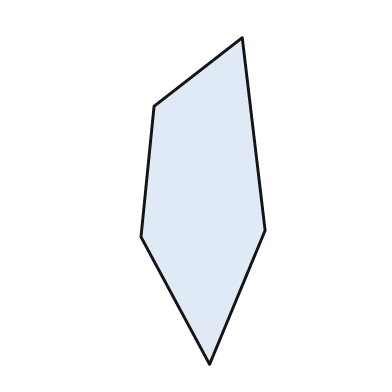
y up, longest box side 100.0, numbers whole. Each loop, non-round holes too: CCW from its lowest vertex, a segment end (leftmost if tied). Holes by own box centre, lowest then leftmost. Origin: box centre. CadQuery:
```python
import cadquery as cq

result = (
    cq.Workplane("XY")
    .moveTo(2.0, -50.0)
    .lineTo(19.0, -9.0)
    .lineTo(12.0, 50.0)
    .lineTo(-15.0, 29.0)
    .lineTo(-19.0, -11.0)
    .close()
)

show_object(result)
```